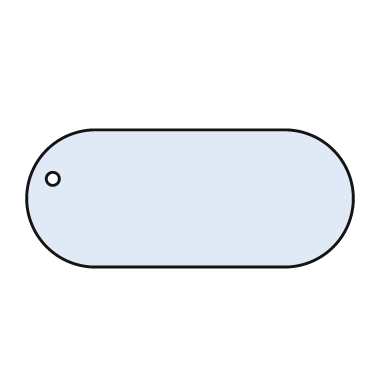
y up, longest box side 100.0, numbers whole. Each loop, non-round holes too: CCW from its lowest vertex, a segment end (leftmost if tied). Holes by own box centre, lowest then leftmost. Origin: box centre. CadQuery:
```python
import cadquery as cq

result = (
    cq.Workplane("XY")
    .moveTo(-29.0, -21.0)
    .lineTo(29.0, -21.0)
    .threePointArc((50.0, 0.0), (29.0, 21.0))
    .lineTo(-29.0, 21.0)
    .threePointArc((-50.0, 0.0), (-29.0, -21.0))
    .close()
    .moveTo(-42.0, 6.0)
    .circle(2.0)
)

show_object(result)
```